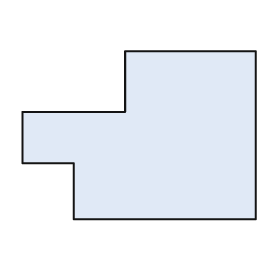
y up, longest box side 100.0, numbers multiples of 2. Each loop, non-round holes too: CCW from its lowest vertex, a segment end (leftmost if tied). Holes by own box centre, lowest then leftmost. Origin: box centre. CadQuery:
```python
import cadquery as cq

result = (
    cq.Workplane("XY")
    .moveTo(-28.0, -36.0)
    .lineTo(50.0, -36.0)
    .lineTo(50.0, 36.0)
    .lineTo(-6.0, 36.0)
    .lineTo(-6.0, 10.0)
    .lineTo(-50.0, 10.0)
    .lineTo(-50.0, -12.0)
    .lineTo(-28.0, -12.0)
    .close()
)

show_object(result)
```